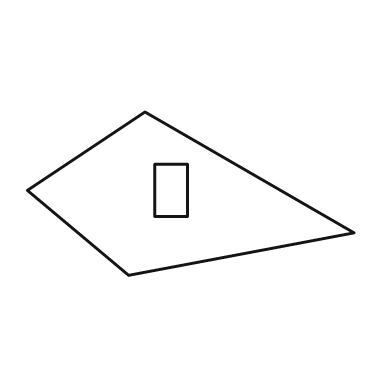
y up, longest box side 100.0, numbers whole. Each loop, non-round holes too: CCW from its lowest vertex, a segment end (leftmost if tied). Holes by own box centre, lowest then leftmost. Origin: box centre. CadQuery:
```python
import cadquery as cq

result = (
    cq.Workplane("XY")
    .moveTo(-19.0, -25.0)
    .lineTo(50.0, -12.0)
    .lineTo(-14.0, 25.0)
    .lineTo(-50.0, 1.0)
    .close()
    .moveTo(-11.0, -7.0)
    .lineTo(-1.0, -7.0)
    .lineTo(-1.0, 9.0)
    .lineTo(-11.0, 9.0)
    .close()
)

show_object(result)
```